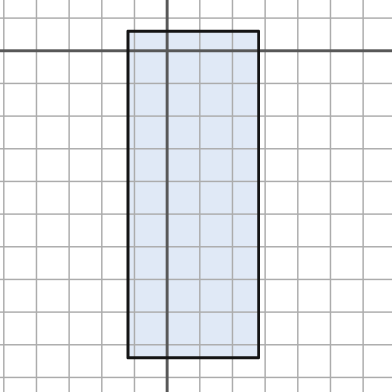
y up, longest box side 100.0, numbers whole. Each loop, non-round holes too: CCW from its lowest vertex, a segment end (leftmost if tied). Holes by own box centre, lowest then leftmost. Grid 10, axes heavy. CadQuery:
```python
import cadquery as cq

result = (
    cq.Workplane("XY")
    .moveTo(-12.0, -94.0)
    .lineTo(28.0, -94.0)
    .lineTo(28.0, 6.0)
    .lineTo(-12.0, 6.0)
    .close()
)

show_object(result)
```